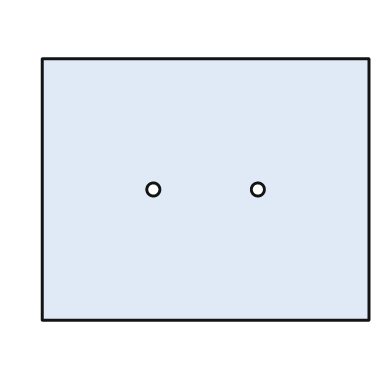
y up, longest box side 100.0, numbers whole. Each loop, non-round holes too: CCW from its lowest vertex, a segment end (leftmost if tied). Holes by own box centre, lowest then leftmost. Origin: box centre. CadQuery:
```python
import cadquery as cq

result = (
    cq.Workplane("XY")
    .moveTo(-50.0, -40.0)
    .lineTo(50.0, -40.0)
    .lineTo(50.0, 40.0)
    .lineTo(-50.0, 40.0)
    .close()
    .moveTo(-16.0, 0.0)
    .circle(2.0)
    .moveTo(16.0, 0.0)
    .circle(2.0)
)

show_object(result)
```